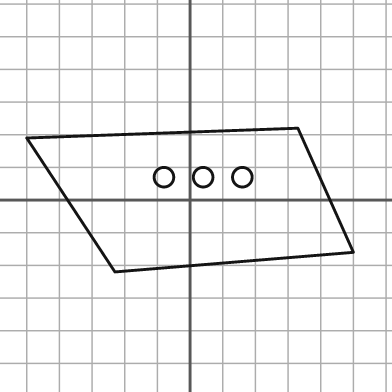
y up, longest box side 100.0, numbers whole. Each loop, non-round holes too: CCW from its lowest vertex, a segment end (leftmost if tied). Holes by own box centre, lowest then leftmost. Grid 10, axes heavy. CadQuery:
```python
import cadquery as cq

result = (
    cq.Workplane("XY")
    .moveTo(-23.0, -22.0)
    .lineTo(50.0, -16.0)
    .lineTo(33.0, 22.0)
    .lineTo(-50.0, 19.0)
    .close()
    .moveTo(-8.0, 7.0)
    .circle(3.0)
    .moveTo(4.0, 7.0)
    .circle(3.0)
    .moveTo(16.0, 7.0)
    .circle(3.0)
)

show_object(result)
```